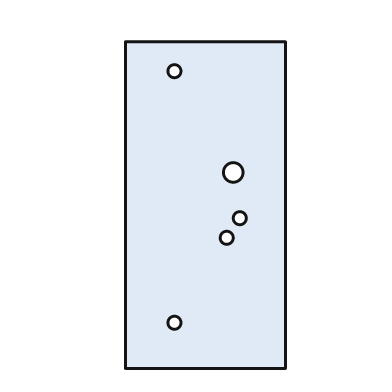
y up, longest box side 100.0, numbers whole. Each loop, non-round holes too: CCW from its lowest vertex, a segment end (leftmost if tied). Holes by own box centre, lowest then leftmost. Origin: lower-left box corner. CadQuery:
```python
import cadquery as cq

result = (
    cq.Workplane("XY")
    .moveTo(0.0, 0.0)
    .lineTo(49.0, 0.0)
    .lineTo(49.0, 100.0)
    .lineTo(0.0, 100.0)
    .close()
    .moveTo(15.0, 14.0)
    .circle(2.0)
    .moveTo(31.0, 40.0)
    .circle(2.0)
    .moveTo(35.0, 46.0)
    .circle(2.0)
    .moveTo(33.0, 60.0)
    .circle(3.0)
    .moveTo(15.0, 91.0)
    .circle(2.0)
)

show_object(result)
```